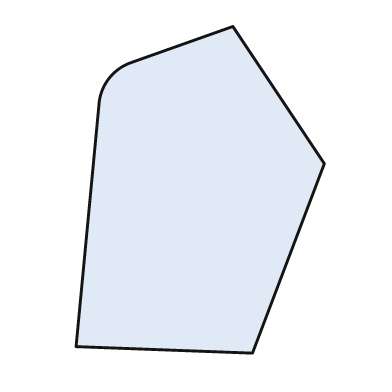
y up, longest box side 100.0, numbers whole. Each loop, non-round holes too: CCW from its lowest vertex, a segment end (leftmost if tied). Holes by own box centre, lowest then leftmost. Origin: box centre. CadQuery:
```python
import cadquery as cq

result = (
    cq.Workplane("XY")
    .moveTo(16.0, -50.0)
    .lineTo(38.0, 8.0)
    .lineTo(10.0, 50.0)
    .lineTo(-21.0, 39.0)
    .threePointArc((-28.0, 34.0), (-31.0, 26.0))
    .lineTo(-38.0, -48.0)
    .close()
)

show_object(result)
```